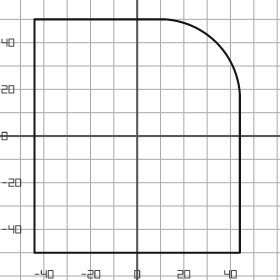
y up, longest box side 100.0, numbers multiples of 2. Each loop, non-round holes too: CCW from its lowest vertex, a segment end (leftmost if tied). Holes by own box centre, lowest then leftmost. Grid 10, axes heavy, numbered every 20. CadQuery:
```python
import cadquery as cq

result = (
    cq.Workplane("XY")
    .moveTo(-44.0, -50.0)
    .lineTo(44.0, -50.0)
    .lineTo(44.0, 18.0)
    .threePointArc((34.0, 40.0), (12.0, 50.0))
    .lineTo(-44.0, 50.0)
    .close()
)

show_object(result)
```